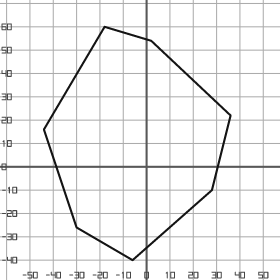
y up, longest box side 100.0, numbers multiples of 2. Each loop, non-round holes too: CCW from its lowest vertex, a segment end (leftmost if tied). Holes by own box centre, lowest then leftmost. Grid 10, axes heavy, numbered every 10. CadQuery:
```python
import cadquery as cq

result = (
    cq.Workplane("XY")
    .moveTo(-6.0, -40.0)
    .lineTo(28.0, -10.0)
    .lineTo(36.0, 22.0)
    .lineTo(2.0, 54.0)
    .lineTo(-18.0, 60.0)
    .lineTo(-44.0, 16.0)
    .lineTo(-30.0, -26.0)
    .close()
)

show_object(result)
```